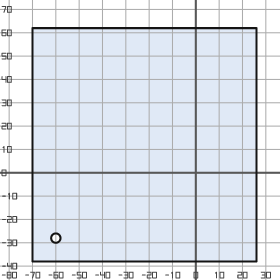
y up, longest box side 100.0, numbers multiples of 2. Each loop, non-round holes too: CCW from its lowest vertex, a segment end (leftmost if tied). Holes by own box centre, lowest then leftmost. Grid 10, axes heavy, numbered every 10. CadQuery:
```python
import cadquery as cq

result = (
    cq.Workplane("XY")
    .moveTo(-70.0, -38.0)
    .lineTo(26.0, -38.0)
    .lineTo(26.0, 62.0)
    .lineTo(-70.0, 62.0)
    .close()
    .moveTo(-60.0, -28.0)
    .circle(2.0)
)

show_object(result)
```